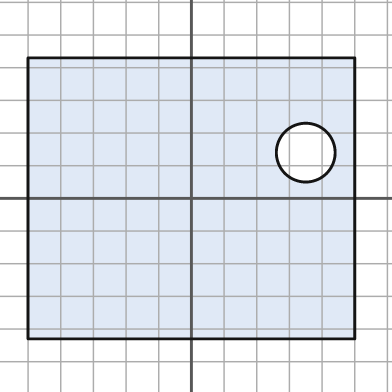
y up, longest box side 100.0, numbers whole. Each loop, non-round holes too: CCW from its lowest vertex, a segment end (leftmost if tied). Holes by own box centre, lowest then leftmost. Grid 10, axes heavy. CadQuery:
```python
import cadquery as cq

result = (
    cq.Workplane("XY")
    .moveTo(-50.0, -43.0)
    .lineTo(50.0, -43.0)
    .lineTo(50.0, 43.0)
    .lineTo(-50.0, 43.0)
    .close()
    .moveTo(35.0, 14.0)
    .circle(9.0)
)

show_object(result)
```